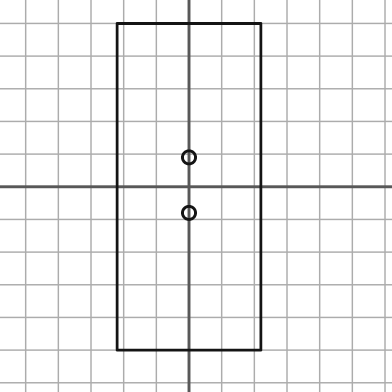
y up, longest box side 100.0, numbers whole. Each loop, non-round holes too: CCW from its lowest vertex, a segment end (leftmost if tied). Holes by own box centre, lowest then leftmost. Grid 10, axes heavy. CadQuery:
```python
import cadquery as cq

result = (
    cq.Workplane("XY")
    .moveTo(-22.0, -50.0)
    .lineTo(22.0, -50.0)
    .lineTo(22.0, 50.0)
    .lineTo(-22.0, 50.0)
    .close()
    .moveTo(0.0, -8.0)
    .circle(2.0)
    .moveTo(0.0, 9.0)
    .circle(2.0)
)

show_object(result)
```